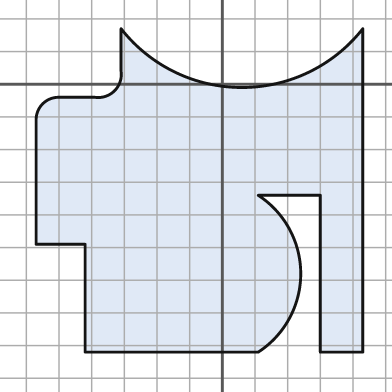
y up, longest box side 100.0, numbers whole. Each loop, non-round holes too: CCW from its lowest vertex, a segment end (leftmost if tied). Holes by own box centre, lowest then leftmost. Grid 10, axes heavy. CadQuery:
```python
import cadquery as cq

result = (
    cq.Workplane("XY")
    .moveTo(-42.0, -82.0)
    .lineTo(11.0, -82.0)
    .threePointArc((24.0, -58.0), (11.0, -34.0))
    .lineTo(30.0, -34.0)
    .lineTo(30.0, -82.0)
    .lineTo(43.0, -82.0)
    .lineTo(43.0, 17.0)
    .threePointArc((6.0, -1.0), (-31.0, 17.0))
    .lineTo(-31.0, 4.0)
    .threePointArc((-33.0, -2.0), (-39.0, -4.0))
    .lineTo(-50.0, -4.0)
    .threePointArc((-55.0, -6.0), (-57.0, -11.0))
    .lineTo(-57.0, -49.0)
    .lineTo(-42.0, -49.0)
    .close()
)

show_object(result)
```